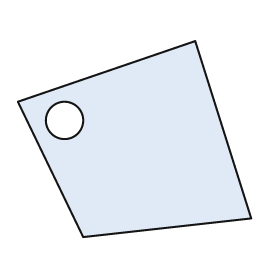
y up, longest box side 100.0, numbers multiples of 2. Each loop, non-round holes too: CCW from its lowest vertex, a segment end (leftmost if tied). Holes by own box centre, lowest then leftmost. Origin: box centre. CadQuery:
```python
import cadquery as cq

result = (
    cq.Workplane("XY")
    .moveTo(-22.0, -42.0)
    .lineTo(50.0, -34.0)
    .lineTo(26.0, 42.0)
    .lineTo(-50.0, 16.0)
    .close()
    .moveTo(-30.0, 8.0)
    .circle(8.0)
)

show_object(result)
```